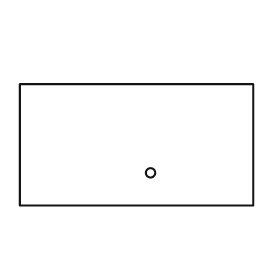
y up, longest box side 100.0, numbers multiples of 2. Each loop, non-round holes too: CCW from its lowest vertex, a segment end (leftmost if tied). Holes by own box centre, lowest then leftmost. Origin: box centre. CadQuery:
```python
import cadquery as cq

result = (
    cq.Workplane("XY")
    .moveTo(-50.0, -26.0)
    .lineTo(50.0, -26.0)
    .lineTo(50.0, 26.0)
    .lineTo(-50.0, 26.0)
    .close()
    .moveTo(6.0, -12.0)
    .circle(2.0)
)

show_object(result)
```